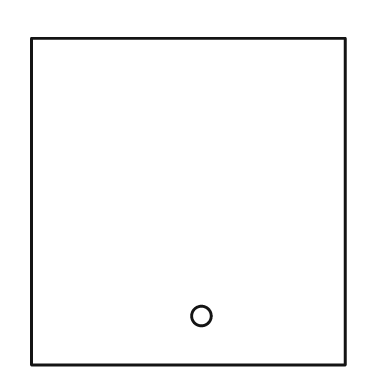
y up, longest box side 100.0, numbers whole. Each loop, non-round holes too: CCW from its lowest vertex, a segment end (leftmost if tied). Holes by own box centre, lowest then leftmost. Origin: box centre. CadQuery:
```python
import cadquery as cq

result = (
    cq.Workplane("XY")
    .moveTo(-48.0, -50.0)
    .lineTo(48.0, -50.0)
    .lineTo(48.0, 50.0)
    .lineTo(-48.0, 50.0)
    .close()
    .moveTo(4.0, -35.0)
    .circle(3.0)
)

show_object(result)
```